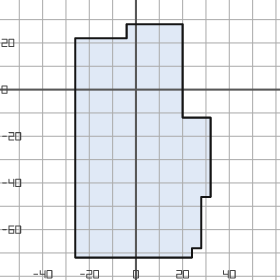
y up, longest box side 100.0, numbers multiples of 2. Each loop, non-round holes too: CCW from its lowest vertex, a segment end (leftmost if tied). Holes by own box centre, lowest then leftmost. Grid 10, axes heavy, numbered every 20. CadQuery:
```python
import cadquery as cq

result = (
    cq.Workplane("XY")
    .moveTo(-26.0, -72.0)
    .lineTo(24.0, -72.0)
    .lineTo(24.0, -68.0)
    .lineTo(28.0, -68.0)
    .lineTo(28.0, -46.0)
    .lineTo(32.0, -46.0)
    .lineTo(32.0, -12.0)
    .lineTo(20.0, -12.0)
    .lineTo(20.0, 28.0)
    .lineTo(-4.0, 28.0)
    .lineTo(-4.0, 22.0)
    .lineTo(-26.0, 22.0)
    .close()
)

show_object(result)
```